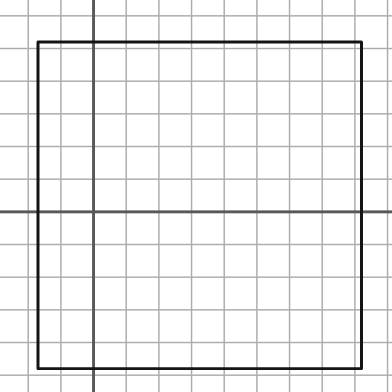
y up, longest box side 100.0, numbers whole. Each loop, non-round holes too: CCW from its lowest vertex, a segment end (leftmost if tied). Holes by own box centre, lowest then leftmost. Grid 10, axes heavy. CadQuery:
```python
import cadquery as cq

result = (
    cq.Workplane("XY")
    .moveTo(-17.0, -48.0)
    .lineTo(82.0, -48.0)
    .lineTo(82.0, 52.0)
    .lineTo(-17.0, 52.0)
    .close()
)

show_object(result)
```